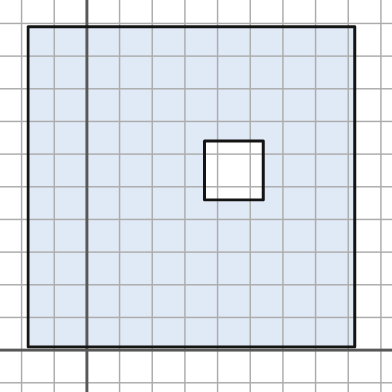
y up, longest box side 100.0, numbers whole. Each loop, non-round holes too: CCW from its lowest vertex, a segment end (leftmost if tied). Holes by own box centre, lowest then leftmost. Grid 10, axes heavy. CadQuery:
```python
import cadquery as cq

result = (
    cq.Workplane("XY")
    .moveTo(-18.0, 1.0)
    .lineTo(82.0, 1.0)
    .lineTo(82.0, 99.0)
    .lineTo(-18.0, 99.0)
    .close()
    .moveTo(36.0, 46.0)
    .lineTo(54.0, 46.0)
    .lineTo(54.0, 64.0)
    .lineTo(36.0, 64.0)
    .close()
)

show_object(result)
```